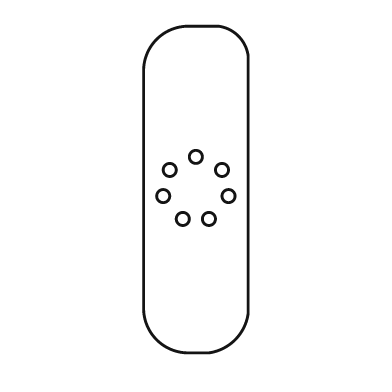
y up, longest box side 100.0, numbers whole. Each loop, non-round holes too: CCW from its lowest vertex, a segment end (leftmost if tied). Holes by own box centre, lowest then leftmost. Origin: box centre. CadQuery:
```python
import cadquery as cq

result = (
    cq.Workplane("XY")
    .moveTo(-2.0, -50.0)
    .lineTo(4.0, -50.0)
    .threePointArc((12.0, -46.0), (16.0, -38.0))
    .lineTo(16.0, 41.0)
    .threePointArc((13.0, 47.0), (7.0, 50.0))
    .lineTo(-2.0, 50.0)
    .threePointArc((-12.0, 46.0), (-16.0, 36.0))
    .lineTo(-16.0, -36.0)
    .threePointArc((-12.0, -46.0), (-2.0, -50.0))
    .close()
    .moveTo(-4.0, -9.0)
    .circle(2.0)
    .moveTo(4.0, -9.0)
    .circle(2.0)
    .moveTo(-10.0, -2.0)
    .circle(2.0)
    .moveTo(10.0, -2.0)
    .circle(2.0)
    .moveTo(-8.0, 6.0)
    .circle(2.0)
    .moveTo(8.0, 6.0)
    .circle(2.0)
    .moveTo(0.0, 10.0)
    .circle(2.0)
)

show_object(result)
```